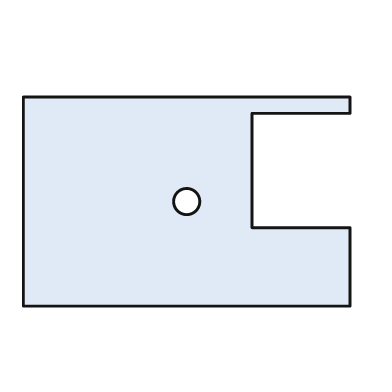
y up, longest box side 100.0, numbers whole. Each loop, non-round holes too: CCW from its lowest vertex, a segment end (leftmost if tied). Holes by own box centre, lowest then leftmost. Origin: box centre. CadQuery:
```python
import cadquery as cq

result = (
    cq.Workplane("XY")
    .moveTo(-50.0, -32.0)
    .lineTo(50.0, -32.0)
    .lineTo(50.0, -8.0)
    .lineTo(20.0, -8.0)
    .lineTo(20.0, 27.0)
    .lineTo(50.0, 27.0)
    .lineTo(50.0, 32.0)
    .lineTo(-50.0, 32.0)
    .close()
    .moveTo(0.0, 0.0)
    .circle(4.0)
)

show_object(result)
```